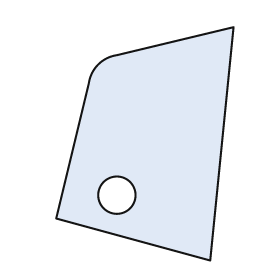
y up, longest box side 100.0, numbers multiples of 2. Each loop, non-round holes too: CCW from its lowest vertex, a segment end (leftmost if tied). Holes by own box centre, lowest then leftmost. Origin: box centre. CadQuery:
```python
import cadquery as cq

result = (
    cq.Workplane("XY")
    .moveTo(28.0, -50.0)
    .lineTo(38.0, 50.0)
    .lineTo(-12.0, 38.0)
    .threePointArc((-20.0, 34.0), (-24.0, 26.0))
    .lineTo(-38.0, -32.0)
    .close()
    .moveTo(-12.0, -22.0)
    .circle(8.0)
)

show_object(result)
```